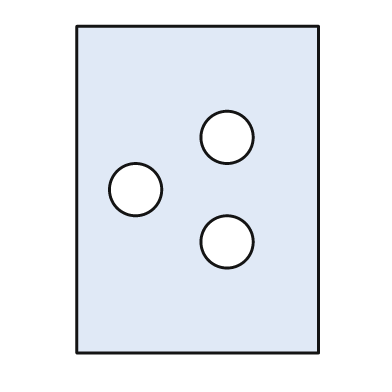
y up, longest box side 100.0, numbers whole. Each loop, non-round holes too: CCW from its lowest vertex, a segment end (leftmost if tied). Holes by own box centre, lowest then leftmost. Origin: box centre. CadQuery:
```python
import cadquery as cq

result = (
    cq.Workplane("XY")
    .moveTo(-37.0, -50.0)
    .lineTo(37.0, -50.0)
    .lineTo(37.0, 50.0)
    .lineTo(-37.0, 50.0)
    .close()
    .moveTo(9.0, -16.0)
    .circle(8.0)
    .moveTo(-19.0, 0.0)
    .circle(8.0)
    .moveTo(9.0, 16.0)
    .circle(8.0)
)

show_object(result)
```